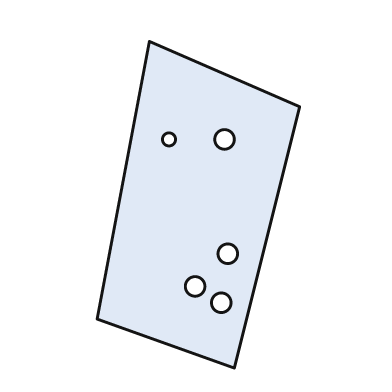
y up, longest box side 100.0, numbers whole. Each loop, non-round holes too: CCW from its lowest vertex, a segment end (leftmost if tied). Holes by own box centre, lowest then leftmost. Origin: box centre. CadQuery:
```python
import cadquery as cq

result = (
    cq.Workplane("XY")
    .moveTo(11.0, -50.0)
    .lineTo(31.0, 30.0)
    .lineTo(-15.0, 50.0)
    .lineTo(-31.0, -35.0)
    .close()
    .moveTo(7.0, -30.0)
    .circle(3.0)
    .moveTo(-1.0, -25.0)
    .circle(3.0)
    .moveTo(9.0, -15.0)
    .circle(3.0)
    .moveTo(-9.0, 20.0)
    .circle(2.0)
    .moveTo(8.0, 20.0)
    .circle(3.0)
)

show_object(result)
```